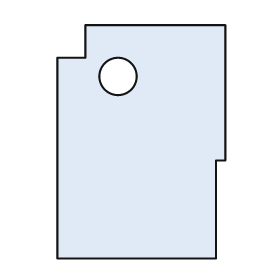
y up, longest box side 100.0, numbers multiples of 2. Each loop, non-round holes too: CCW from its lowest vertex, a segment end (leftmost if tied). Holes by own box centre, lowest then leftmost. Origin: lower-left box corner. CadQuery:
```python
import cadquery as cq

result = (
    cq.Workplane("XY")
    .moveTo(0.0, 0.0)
    .lineTo(68.0, 0.0)
    .lineTo(68.0, 42.0)
    .lineTo(72.0, 42.0)
    .lineTo(72.0, 100.0)
    .lineTo(12.0, 100.0)
    .lineTo(12.0, 86.0)
    .lineTo(0.0, 86.0)
    .close()
    .moveTo(26.0, 78.0)
    .circle(8.0)
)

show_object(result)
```